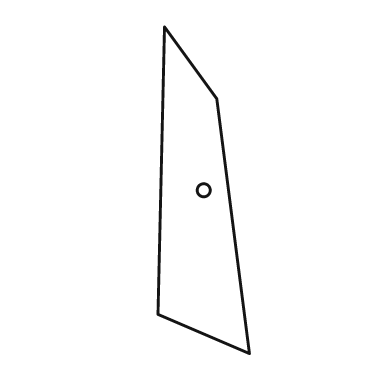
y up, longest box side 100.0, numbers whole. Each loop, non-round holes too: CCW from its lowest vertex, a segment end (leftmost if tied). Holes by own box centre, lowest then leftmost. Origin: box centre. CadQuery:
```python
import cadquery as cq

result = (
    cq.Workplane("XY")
    .moveTo(14.0, -50.0)
    .lineTo(4.0, 28.0)
    .lineTo(-12.0, 50.0)
    .lineTo(-14.0, -38.0)
    .close()
    .moveTo(0.0, 0.0)
    .circle(2.0)
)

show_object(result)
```